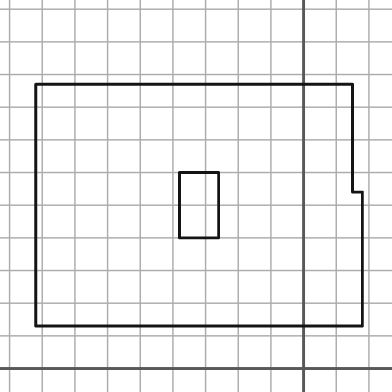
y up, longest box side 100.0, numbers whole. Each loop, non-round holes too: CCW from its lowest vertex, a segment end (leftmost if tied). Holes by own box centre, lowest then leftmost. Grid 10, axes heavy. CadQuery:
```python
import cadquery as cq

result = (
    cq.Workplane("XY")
    .moveTo(-82.0, 13.0)
    .lineTo(18.0, 13.0)
    .lineTo(18.0, 54.0)
    .lineTo(15.0, 54.0)
    .lineTo(15.0, 87.0)
    .lineTo(-82.0, 87.0)
    .close()
    .moveTo(-38.0, 40.0)
    .lineTo(-26.0, 40.0)
    .lineTo(-26.0, 60.0)
    .lineTo(-38.0, 60.0)
    .close()
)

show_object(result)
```